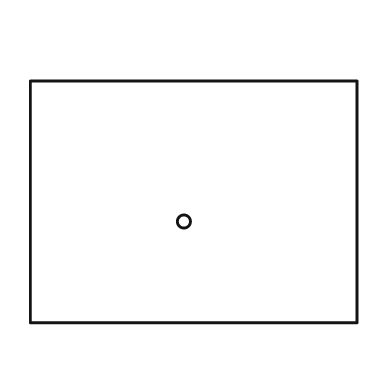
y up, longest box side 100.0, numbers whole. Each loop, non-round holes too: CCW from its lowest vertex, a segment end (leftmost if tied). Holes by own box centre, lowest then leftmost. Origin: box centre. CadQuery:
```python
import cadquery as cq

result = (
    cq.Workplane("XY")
    .moveTo(-50.0, -37.0)
    .lineTo(50.0, -37.0)
    .lineTo(50.0, 37.0)
    .lineTo(-50.0, 37.0)
    .close()
    .moveTo(-3.0, -6.0)
    .circle(2.0)
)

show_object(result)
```